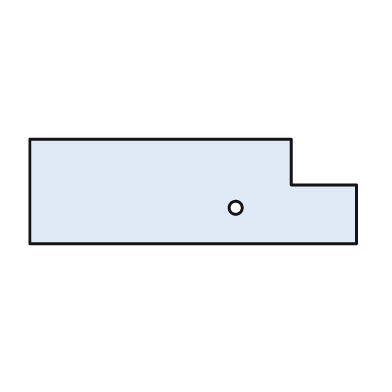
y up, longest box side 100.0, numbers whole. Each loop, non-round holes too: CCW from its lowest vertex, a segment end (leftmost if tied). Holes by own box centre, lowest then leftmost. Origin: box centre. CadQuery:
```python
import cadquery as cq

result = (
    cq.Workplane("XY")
    .moveTo(-50.0, -16.0)
    .lineTo(50.0, -16.0)
    .lineTo(50.0, 2.0)
    .lineTo(30.0, 2.0)
    .lineTo(30.0, 16.0)
    .lineTo(-50.0, 16.0)
    .close()
    .moveTo(13.0, -5.0)
    .circle(2.0)
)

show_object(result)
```